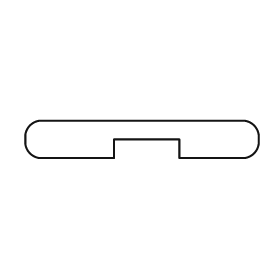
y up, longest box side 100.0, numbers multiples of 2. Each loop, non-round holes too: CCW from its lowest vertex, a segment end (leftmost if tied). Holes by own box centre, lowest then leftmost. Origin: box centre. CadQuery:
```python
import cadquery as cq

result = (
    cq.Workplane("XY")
    .moveTo(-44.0, -8.0)
    .lineTo(-12.0, -8.0)
    .lineTo(-12.0, 0.0)
    .lineTo(16.0, 0.0)
    .lineTo(16.0, -8.0)
    .lineTo(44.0, -8.0)
    .threePointArc((48.0, -6.0), (50.0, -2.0))
    .lineTo(50.0, 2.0)
    .threePointArc((48.0, 6.0), (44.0, 8.0))
    .lineTo(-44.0, 8.0)
    .threePointArc((-48.0, 6.0), (-50.0, 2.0))
    .lineTo(-50.0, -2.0)
    .threePointArc((-48.0, -6.0), (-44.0, -8.0))
    .close()
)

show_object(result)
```